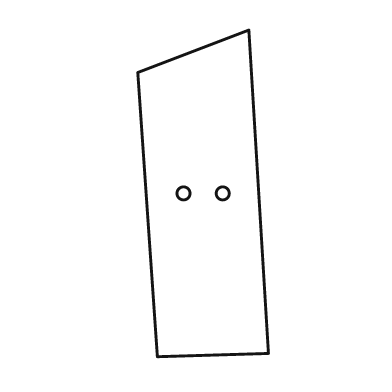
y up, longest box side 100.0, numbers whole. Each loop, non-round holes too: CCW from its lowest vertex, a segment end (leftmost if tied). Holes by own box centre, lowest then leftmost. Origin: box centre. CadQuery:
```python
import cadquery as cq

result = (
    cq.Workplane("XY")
    .moveTo(-14.0, -50.0)
    .lineTo(20.0, -49.0)
    .lineTo(14.0, 50.0)
    .lineTo(-20.0, 37.0)
    .close()
    .moveTo(-6.0, 0.0)
    .circle(2.0)
    .moveTo(6.0, 0.0)
    .circle(2.0)
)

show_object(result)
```